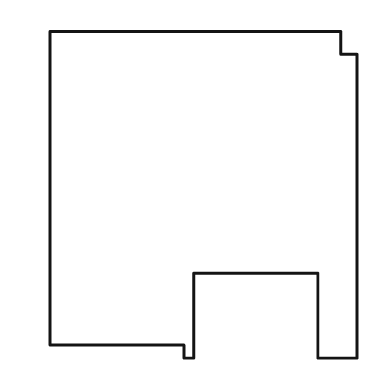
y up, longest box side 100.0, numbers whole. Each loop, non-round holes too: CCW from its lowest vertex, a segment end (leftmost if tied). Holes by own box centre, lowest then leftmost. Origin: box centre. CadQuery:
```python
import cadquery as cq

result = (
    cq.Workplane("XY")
    .moveTo(-6.0, -50.0)
    .lineTo(-3.0, -50.0)
    .lineTo(-3.0, -24.0)
    .lineTo(35.0, -24.0)
    .lineTo(35.0, -50.0)
    .lineTo(47.0, -50.0)
    .lineTo(47.0, 43.0)
    .lineTo(42.0, 43.0)
    .lineTo(42.0, 50.0)
    .lineTo(-47.0, 50.0)
    .lineTo(-47.0, -46.0)
    .lineTo(-6.0, -46.0)
    .close()
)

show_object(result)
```